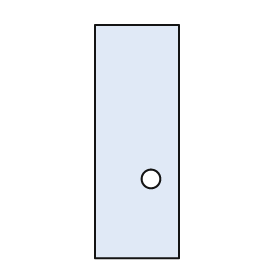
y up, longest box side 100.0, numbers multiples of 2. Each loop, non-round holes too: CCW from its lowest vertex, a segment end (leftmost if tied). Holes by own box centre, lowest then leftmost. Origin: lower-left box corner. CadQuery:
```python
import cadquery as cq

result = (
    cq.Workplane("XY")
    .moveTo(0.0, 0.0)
    .lineTo(36.0, 0.0)
    .lineTo(36.0, 100.0)
    .lineTo(0.0, 100.0)
    .close()
    .moveTo(24.0, 34.0)
    .circle(4.0)
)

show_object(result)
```